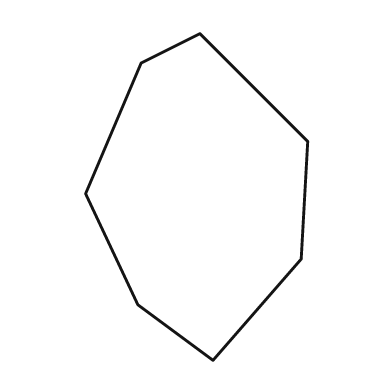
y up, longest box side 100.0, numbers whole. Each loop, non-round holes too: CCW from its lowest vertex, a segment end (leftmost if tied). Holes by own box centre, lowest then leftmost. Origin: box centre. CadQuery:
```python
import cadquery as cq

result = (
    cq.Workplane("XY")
    .moveTo(5.0, -50.0)
    .lineTo(32.0, -19.0)
    .lineTo(34.0, 17.0)
    .lineTo(1.0, 50.0)
    .lineTo(-17.0, 41.0)
    .lineTo(-34.0, 1.0)
    .lineTo(-18.0, -33.0)
    .close()
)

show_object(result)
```